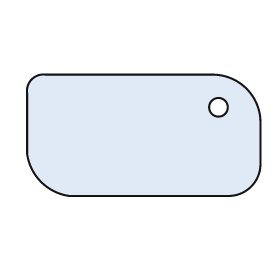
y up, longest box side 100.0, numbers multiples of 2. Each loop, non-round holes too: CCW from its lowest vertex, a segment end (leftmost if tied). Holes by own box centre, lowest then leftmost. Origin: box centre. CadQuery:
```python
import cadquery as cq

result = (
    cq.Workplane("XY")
    .moveTo(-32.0, -26.0)
    .lineTo(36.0, -26.0)
    .threePointArc((46.0, -22.0), (50.0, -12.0))
    .lineTo(50.0, 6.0)
    .threePointArc((44.0, 20.0), (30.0, 26.0))
    .lineTo(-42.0, 26.0)
    .threePointArc((-48.0, 24.0), (-50.0, 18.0))
    .lineTo(-50.0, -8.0)
    .threePointArc((-44.0, -20.0), (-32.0, -26.0))
    .close()
    .moveTo(32.0, 12.0)
    .circle(4.0)
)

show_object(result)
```